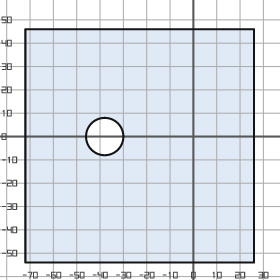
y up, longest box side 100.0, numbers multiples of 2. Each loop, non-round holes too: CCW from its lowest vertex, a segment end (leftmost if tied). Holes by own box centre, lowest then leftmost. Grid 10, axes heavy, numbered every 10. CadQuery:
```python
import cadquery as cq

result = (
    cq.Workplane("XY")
    .moveTo(-72.0, -54.0)
    .lineTo(26.0, -54.0)
    .lineTo(26.0, 46.0)
    .lineTo(-72.0, 46.0)
    .close()
    .moveTo(-38.0, 0.0)
    .circle(8.0)
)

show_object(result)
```